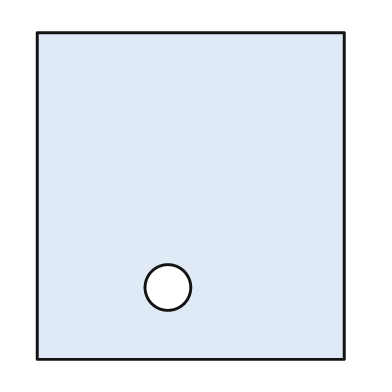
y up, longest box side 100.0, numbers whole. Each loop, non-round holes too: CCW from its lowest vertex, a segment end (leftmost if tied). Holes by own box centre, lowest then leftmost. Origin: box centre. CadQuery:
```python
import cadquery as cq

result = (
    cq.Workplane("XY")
    .moveTo(-47.0, -50.0)
    .lineTo(47.0, -50.0)
    .lineTo(47.0, 50.0)
    .lineTo(-47.0, 50.0)
    .close()
    .moveTo(-7.0, -28.0)
    .circle(7.0)
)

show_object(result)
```